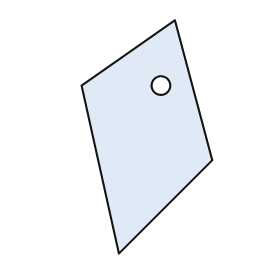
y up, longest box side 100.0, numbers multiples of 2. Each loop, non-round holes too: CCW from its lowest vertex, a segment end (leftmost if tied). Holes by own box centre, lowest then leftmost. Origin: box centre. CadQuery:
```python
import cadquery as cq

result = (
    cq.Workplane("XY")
    .moveTo(-12.0, -50.0)
    .lineTo(28.0, -10.0)
    .lineTo(12.0, 50.0)
    .lineTo(-28.0, 22.0)
    .close()
    .moveTo(6.0, 22.0)
    .circle(4.0)
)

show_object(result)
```